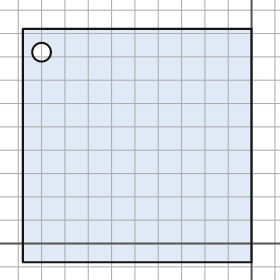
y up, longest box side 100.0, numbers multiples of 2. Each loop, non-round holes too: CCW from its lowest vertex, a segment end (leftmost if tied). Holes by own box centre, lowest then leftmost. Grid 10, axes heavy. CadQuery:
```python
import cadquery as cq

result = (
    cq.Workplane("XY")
    .moveTo(-98.0, -8.0)
    .lineTo(0.0, -8.0)
    .lineTo(0.0, 92.0)
    .lineTo(-98.0, 92.0)
    .close()
    .moveTo(-90.0, 82.0)
    .circle(4.0)
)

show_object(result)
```